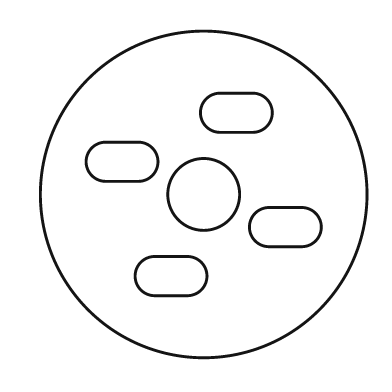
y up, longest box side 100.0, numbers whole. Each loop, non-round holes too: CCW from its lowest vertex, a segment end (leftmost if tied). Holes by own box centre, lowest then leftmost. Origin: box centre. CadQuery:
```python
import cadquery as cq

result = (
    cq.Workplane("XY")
    .moveTo(0.0, 0.0)
    .circle(50.0)
    .moveTo(-15.0, -31.0)
    .lineTo(-5.0, -31.0)
    .threePointArc((1.0, -25.0), (-5.0, -19.0))
    .lineTo(-15.0, -19.0)
    .threePointArc((-21.0, -25.0), (-15.0, -31.0))
    .close()
    .moveTo(20.0, -16.0)
    .lineTo(30.0, -16.0)
    .threePointArc((36.0, -10.0), (30.0, -4.0))
    .lineTo(20.0, -4.0)
    .threePointArc((14.0, -10.0), (20.0, -16.0))
    .close()
    .moveTo(0.0, 0.0)
    .circle(11.0)
    .moveTo(-30.0, 4.0)
    .lineTo(-20.0, 4.0)
    .threePointArc((-14.0, 10.0), (-20.0, 16.0))
    .lineTo(-30.0, 16.0)
    .threePointArc((-36.0, 10.0), (-30.0, 4.0))
    .close()
    .moveTo(5.0, 19.0)
    .lineTo(15.0, 19.0)
    .threePointArc((21.0, 25.0), (15.0, 31.0))
    .lineTo(5.0, 31.0)
    .threePointArc((-1.0, 25.0), (5.0, 19.0))
    .close()
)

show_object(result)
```